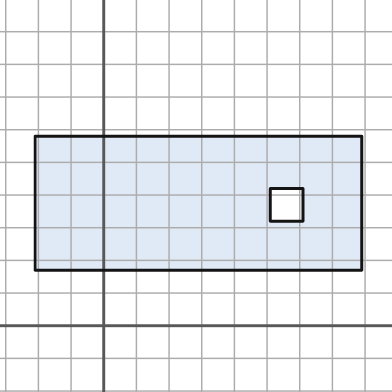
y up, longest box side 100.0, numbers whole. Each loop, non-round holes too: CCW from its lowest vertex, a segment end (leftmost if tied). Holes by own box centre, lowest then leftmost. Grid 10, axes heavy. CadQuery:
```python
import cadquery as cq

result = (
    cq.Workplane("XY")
    .moveTo(-21.0, 17.0)
    .lineTo(79.0, 17.0)
    .lineTo(79.0, 58.0)
    .lineTo(-21.0, 58.0)
    .close()
    .moveTo(51.0, 32.0)
    .lineTo(61.0, 32.0)
    .lineTo(61.0, 42.0)
    .lineTo(51.0, 42.0)
    .close()
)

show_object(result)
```